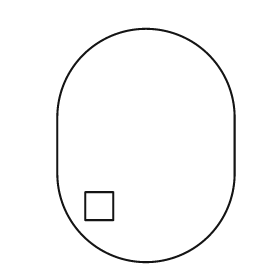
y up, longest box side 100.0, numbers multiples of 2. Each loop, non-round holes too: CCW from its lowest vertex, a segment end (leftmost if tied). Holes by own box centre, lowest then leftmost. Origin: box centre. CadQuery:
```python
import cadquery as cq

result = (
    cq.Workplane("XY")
    .moveTo(-38.0, -12.0)
    .threePointArc((0.0, -50.0), (38.0, -12.0))
    .lineTo(38.0, 12.0)
    .threePointArc((0.0, 50.0), (-38.0, 12.0))
    .close()
    .moveTo(-26.0, -32.0)
    .lineTo(-14.0, -32.0)
    .lineTo(-14.0, -20.0)
    .lineTo(-26.0, -20.0)
    .close()
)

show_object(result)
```